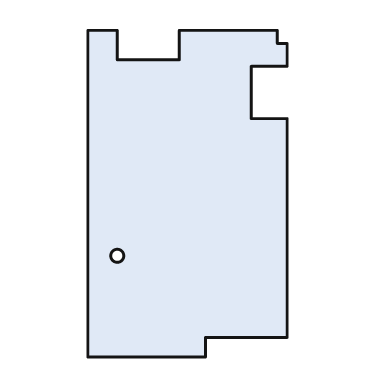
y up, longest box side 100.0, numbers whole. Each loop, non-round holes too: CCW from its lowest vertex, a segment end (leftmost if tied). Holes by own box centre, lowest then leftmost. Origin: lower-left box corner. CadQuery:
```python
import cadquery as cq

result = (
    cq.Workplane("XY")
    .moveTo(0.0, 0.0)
    .lineTo(36.0, 0.0)
    .lineTo(36.0, 6.0)
    .lineTo(61.0, 6.0)
    .lineTo(61.0, 73.0)
    .lineTo(50.0, 73.0)
    .lineTo(50.0, 89.0)
    .lineTo(61.0, 89.0)
    .lineTo(61.0, 96.0)
    .lineTo(58.0, 96.0)
    .lineTo(58.0, 100.0)
    .lineTo(28.0, 100.0)
    .lineTo(28.0, 91.0)
    .lineTo(9.0, 91.0)
    .lineTo(9.0, 100.0)
    .lineTo(0.0, 100.0)
    .close()
    .moveTo(9.0, 31.0)
    .circle(2.0)
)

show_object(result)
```